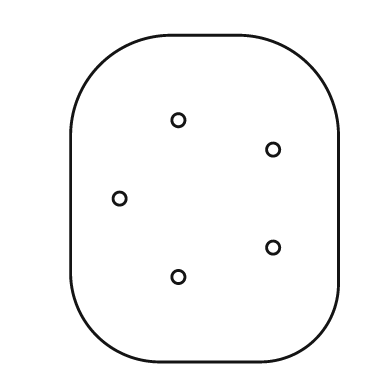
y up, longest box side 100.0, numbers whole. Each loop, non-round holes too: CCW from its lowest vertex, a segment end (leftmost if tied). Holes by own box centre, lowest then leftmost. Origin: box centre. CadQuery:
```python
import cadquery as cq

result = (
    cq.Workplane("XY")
    .moveTo(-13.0, -50.0)
    .lineTo(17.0, -50.0)
    .threePointArc((34.0, -43.0), (41.0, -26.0))
    .lineTo(41.0, 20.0)
    .threePointArc((32.0, 41.0), (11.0, 50.0))
    .lineTo(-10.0, 50.0)
    .threePointArc((-32.0, 41.0), (-41.0, 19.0))
    .lineTo(-41.0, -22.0)
    .threePointArc((-33.0, -42.0), (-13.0, -50.0))
    .close()
    .moveTo(-8.0, -24.0)
    .circle(2.0)
    .moveTo(21.0, -15.0)
    .circle(2.0)
    .moveTo(-26.0, 0.0)
    .circle(2.0)
    .moveTo(21.0, 15.0)
    .circle(2.0)
    .moveTo(-8.0, 24.0)
    .circle(2.0)
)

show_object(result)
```